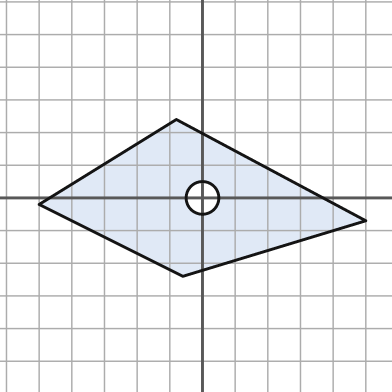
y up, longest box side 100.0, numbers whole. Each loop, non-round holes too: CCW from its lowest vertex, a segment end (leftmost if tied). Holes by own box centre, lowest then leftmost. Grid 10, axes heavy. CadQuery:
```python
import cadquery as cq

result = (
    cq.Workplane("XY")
    .moveTo(-6.0, -24.0)
    .lineTo(50.0, -7.0)
    .lineTo(-8.0, 24.0)
    .lineTo(-50.0, -2.0)
    .close()
    .moveTo(0.0, 0.0)
    .circle(5.0)
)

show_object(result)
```